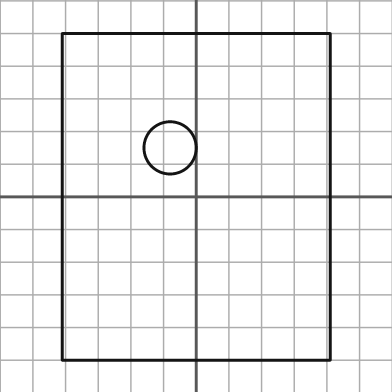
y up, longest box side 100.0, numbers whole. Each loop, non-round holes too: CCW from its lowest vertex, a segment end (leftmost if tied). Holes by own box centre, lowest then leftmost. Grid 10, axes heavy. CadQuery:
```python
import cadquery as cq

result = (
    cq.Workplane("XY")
    .moveTo(-41.0, -50.0)
    .lineTo(41.0, -50.0)
    .lineTo(41.0, 50.0)
    .lineTo(-41.0, 50.0)
    .close()
    .moveTo(-8.0, 15.0)
    .circle(8.0)
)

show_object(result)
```